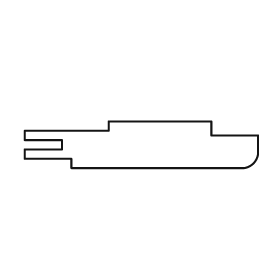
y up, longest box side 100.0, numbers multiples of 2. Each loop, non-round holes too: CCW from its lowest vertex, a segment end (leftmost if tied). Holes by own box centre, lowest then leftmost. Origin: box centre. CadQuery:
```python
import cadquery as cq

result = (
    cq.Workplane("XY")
    .moveTo(-30.0, -10.0)
    .lineTo(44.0, -10.0)
    .threePointArc((48.0, -8.0), (50.0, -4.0))
    .lineTo(50.0, 4.0)
    .lineTo(30.0, 4.0)
    .lineTo(30.0, 10.0)
    .lineTo(-14.0, 10.0)
    .lineTo(-14.0, 6.0)
    .lineTo(-50.0, 6.0)
    .lineTo(-50.0, 2.0)
    .lineTo(-34.0, 2.0)
    .lineTo(-34.0, -2.0)
    .lineTo(-50.0, -2.0)
    .lineTo(-50.0, -6.0)
    .lineTo(-30.0, -6.0)
    .close()
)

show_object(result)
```